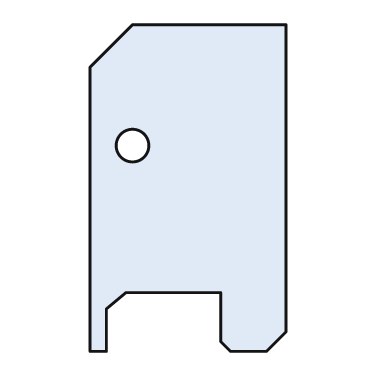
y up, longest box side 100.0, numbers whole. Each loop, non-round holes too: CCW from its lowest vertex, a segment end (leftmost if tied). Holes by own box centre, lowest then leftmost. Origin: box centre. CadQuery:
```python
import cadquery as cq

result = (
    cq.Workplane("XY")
    .moveTo(-30.0, -50.0)
    .lineTo(-25.0, -50.0)
    .lineTo(-25.0, -37.0)
    .lineTo(-19.0, -32.0)
    .lineTo(10.0, -32.0)
    .lineTo(10.0, -47.0)
    .lineTo(13.0, -50.0)
    .lineTo(24.0, -50.0)
    .lineTo(30.0, -44.0)
    .lineTo(30.0, 50.0)
    .lineTo(-17.0, 50.0)
    .lineTo(-30.0, 37.0)
    .close()
    .moveTo(-17.0, 13.0)
    .circle(5.0)
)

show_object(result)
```